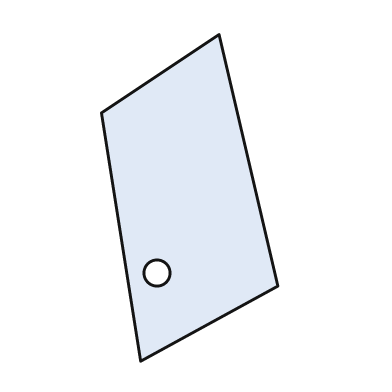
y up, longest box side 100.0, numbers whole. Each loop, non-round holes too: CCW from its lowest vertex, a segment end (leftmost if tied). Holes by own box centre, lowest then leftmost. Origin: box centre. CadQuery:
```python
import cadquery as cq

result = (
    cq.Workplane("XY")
    .moveTo(-15.0, -50.0)
    .lineTo(27.0, -27.0)
    .lineTo(9.0, 50.0)
    .lineTo(-27.0, 26.0)
    .close()
    .moveTo(-10.0, -23.0)
    .circle(4.0)
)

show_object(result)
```